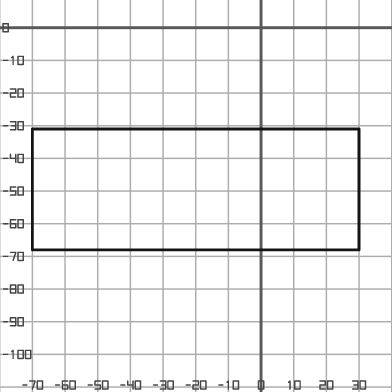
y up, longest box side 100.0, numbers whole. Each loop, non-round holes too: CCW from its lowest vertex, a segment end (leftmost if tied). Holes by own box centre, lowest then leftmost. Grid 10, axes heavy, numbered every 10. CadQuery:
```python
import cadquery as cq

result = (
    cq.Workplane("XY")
    .moveTo(-70.0, -68.0)
    .lineTo(30.0, -68.0)
    .lineTo(30.0, -31.0)
    .lineTo(-70.0, -31.0)
    .close()
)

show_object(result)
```